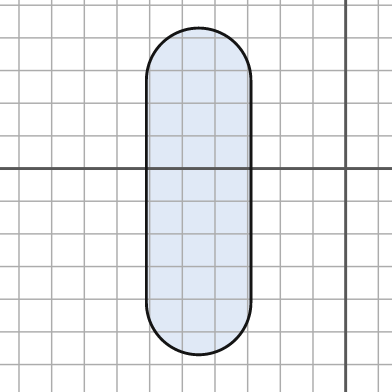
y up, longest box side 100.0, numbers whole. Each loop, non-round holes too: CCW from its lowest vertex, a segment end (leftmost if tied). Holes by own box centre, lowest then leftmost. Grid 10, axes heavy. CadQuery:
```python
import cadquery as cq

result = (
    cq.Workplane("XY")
    .moveTo(-61.0, -41.0)
    .threePointArc((-45.0, -57.0), (-29.0, -41.0))
    .lineTo(-29.0, 27.0)
    .threePointArc((-45.0, 43.0), (-61.0, 27.0))
    .close()
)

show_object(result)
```